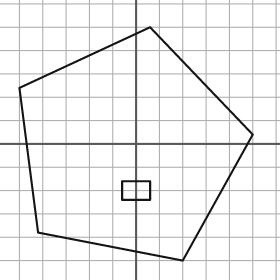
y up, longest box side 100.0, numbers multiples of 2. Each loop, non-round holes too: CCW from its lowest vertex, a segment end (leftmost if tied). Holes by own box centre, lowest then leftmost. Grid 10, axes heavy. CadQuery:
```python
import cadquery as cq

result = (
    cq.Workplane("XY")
    .moveTo(20.0, -50.0)
    .lineTo(50.0, 4.0)
    .lineTo(6.0, 50.0)
    .lineTo(-50.0, 24.0)
    .lineTo(-42.0, -38.0)
    .close()
    .moveTo(-6.0, -24.0)
    .lineTo(6.0, -24.0)
    .lineTo(6.0, -16.0)
    .lineTo(-6.0, -16.0)
    .close()
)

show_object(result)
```